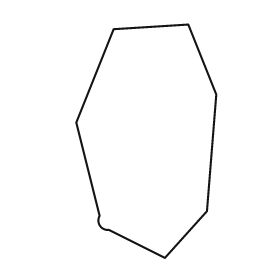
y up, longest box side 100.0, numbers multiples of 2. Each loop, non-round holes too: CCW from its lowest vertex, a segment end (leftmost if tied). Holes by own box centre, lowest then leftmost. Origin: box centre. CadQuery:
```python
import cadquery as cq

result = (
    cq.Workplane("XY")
    .moveTo(8.0, -50.0)
    .lineTo(26.0, -30.0)
    .lineTo(30.0, 20.0)
    .lineTo(18.0, 50.0)
    .lineTo(-14.0, 48.0)
    .lineTo(-30.0, 8.0)
    .lineTo(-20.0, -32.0)
    .threePointArc((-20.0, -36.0), (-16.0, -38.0))
    .close()
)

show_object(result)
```